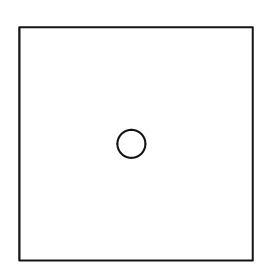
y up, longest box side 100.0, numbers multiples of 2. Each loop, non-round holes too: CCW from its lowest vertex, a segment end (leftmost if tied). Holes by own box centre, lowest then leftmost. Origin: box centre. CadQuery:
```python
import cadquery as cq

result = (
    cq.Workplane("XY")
    .moveTo(-50.0, -50.0)
    .lineTo(50.0, -50.0)
    .lineTo(50.0, 50.0)
    .lineTo(-50.0, 50.0)
    .close()
    .moveTo(-2.0, 0.0)
    .circle(6.0)
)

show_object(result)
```